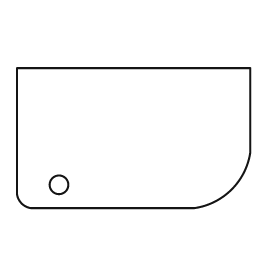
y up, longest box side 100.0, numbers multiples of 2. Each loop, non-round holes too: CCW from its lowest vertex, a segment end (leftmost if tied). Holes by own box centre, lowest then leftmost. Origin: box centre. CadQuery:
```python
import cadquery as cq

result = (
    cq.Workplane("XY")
    .moveTo(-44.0, -30.0)
    .lineTo(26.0, -30.0)
    .threePointArc((42.0, -22.0), (50.0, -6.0))
    .lineTo(50.0, 30.0)
    .lineTo(-50.0, 30.0)
    .lineTo(-50.0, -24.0)
    .threePointArc((-48.0, -28.0), (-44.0, -30.0))
    .close()
    .moveTo(-32.0, -20.0)
    .circle(4.0)
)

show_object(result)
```